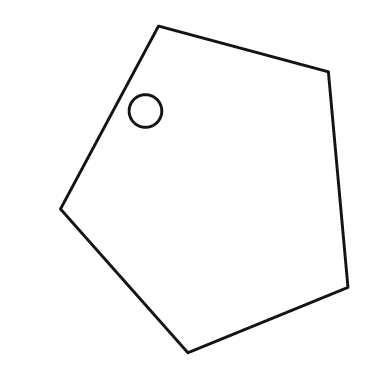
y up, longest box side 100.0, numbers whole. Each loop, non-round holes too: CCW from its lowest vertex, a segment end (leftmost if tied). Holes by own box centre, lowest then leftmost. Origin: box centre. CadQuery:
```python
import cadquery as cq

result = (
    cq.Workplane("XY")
    .moveTo(-5.0, -50.0)
    .lineTo(44.0, -30.0)
    .lineTo(38.0, 36.0)
    .lineTo(-14.0, 50.0)
    .lineTo(-44.0, -6.0)
    .close()
    .moveTo(-18.0, 24.0)
    .circle(5.0)
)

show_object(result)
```